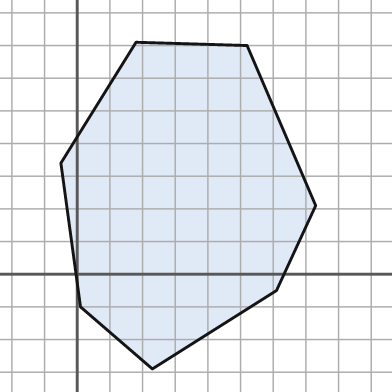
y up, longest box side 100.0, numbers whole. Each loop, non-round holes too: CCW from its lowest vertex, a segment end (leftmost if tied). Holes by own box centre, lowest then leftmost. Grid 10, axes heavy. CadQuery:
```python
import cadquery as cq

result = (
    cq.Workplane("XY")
    .moveTo(23.0, -29.0)
    .lineTo(61.0, -5.0)
    .lineTo(73.0, 21.0)
    .lineTo(52.0, 70.0)
    .lineTo(18.0, 71.0)
    .lineTo(-5.0, 34.0)
    .lineTo(1.0, -10.0)
    .close()
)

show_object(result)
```